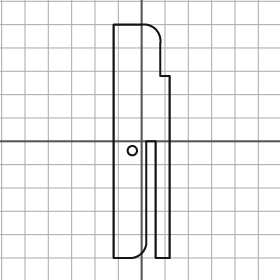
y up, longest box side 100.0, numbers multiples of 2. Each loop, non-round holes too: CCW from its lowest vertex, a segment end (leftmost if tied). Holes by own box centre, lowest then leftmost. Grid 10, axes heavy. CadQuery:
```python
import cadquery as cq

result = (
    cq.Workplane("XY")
    .moveTo(-12.0, -50.0)
    .lineTo(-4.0, -50.0)
    .threePointArc((0.0, -48.0), (2.0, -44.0))
    .lineTo(2.0, 0.0)
    .lineTo(6.0, 0.0)
    .lineTo(6.0, -50.0)
    .lineTo(12.0, -50.0)
    .lineTo(12.0, 28.0)
    .lineTo(8.0, 28.0)
    .lineTo(8.0, 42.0)
    .threePointArc((6.0, 48.0), (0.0, 50.0))
    .lineTo(-12.0, 50.0)
    .close()
    .moveTo(-4.0, -4.0)
    .circle(2.0)
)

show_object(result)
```